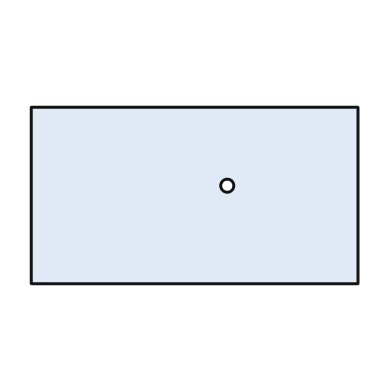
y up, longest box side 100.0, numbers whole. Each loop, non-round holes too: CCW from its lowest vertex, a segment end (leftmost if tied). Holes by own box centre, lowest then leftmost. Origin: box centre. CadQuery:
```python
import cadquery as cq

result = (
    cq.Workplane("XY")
    .moveTo(-50.0, -27.0)
    .lineTo(50.0, -27.0)
    .lineTo(50.0, 27.0)
    .lineTo(-50.0, 27.0)
    .close()
    .moveTo(10.0, 3.0)
    .circle(2.0)
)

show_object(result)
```